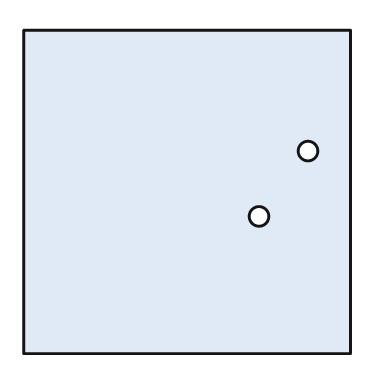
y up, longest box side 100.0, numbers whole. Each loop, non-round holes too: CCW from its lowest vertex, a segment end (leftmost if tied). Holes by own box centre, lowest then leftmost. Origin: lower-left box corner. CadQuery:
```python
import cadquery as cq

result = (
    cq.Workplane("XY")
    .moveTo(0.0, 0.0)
    .lineTo(100.0, 0.0)
    .lineTo(100.0, 99.0)
    .lineTo(0.0, 99.0)
    .close()
    .moveTo(72.0, 42.0)
    .circle(3.0)
    .moveTo(87.0, 62.0)
    .circle(3.0)
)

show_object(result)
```